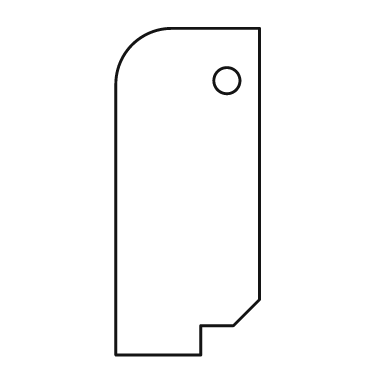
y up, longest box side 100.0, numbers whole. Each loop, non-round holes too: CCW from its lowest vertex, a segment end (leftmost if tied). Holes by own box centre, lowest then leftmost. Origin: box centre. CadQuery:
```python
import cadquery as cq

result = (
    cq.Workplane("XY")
    .moveTo(-22.0, -50.0)
    .lineTo(4.0, -50.0)
    .lineTo(4.0, -41.0)
    .lineTo(14.0, -41.0)
    .lineTo(22.0, -33.0)
    .lineTo(22.0, 50.0)
    .lineTo(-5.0, 50.0)
    .threePointArc((-17.0, 45.0), (-22.0, 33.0))
    .close()
    .moveTo(12.0, 34.0)
    .circle(4.0)
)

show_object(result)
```